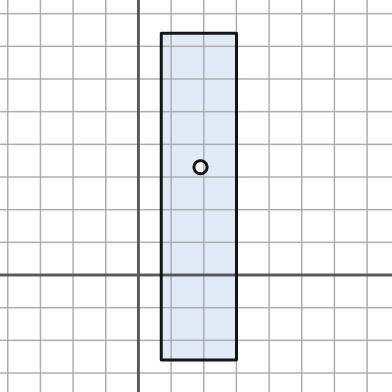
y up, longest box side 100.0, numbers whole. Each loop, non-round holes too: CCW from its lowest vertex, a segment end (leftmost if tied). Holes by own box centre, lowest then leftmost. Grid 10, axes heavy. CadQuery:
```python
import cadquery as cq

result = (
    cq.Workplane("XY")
    .moveTo(7.0, -26.0)
    .lineTo(30.0, -26.0)
    .lineTo(30.0, 74.0)
    .lineTo(7.0, 74.0)
    .close()
    .moveTo(19.0, 33.0)
    .circle(2.0)
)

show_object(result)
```